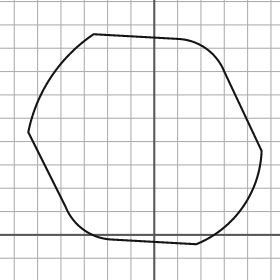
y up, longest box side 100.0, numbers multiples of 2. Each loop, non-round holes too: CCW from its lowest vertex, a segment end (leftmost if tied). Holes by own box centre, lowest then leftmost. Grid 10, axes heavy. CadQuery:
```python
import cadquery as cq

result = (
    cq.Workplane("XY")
    .moveTo(18.0, -4.0)
    .threePointArc((38.0, 12.0), (46.0, 36.0))
    .lineTo(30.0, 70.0)
    .threePointArc((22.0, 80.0), (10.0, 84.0))
    .lineTo(-26.0, 86.0)
    .threePointArc((-44.0, 68.0), (-54.0, 44.0))
    .lineTo(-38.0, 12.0)
    .threePointArc((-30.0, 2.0), (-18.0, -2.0))
    .close()
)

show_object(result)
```